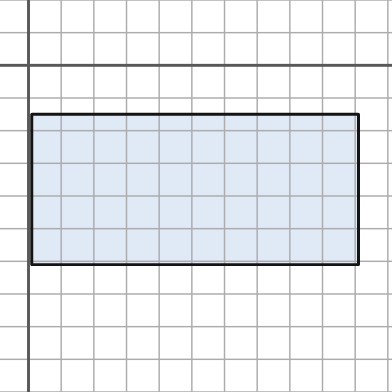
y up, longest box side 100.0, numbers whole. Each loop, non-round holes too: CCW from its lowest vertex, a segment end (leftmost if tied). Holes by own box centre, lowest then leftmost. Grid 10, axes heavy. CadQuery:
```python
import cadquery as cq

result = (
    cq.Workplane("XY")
    .moveTo(1.0, -61.0)
    .lineTo(101.0, -61.0)
    .lineTo(101.0, -15.0)
    .lineTo(1.0, -15.0)
    .close()
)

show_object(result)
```